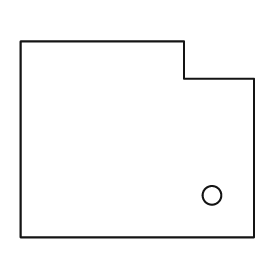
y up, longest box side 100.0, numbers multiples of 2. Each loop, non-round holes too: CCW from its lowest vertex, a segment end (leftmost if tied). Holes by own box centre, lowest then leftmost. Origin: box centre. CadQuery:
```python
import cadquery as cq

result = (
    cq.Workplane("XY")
    .moveTo(-50.0, -42.0)
    .lineTo(50.0, -42.0)
    .lineTo(50.0, 26.0)
    .lineTo(20.0, 26.0)
    .lineTo(20.0, 42.0)
    .lineTo(-50.0, 42.0)
    .close()
    .moveTo(32.0, -24.0)
    .circle(4.0)
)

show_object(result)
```